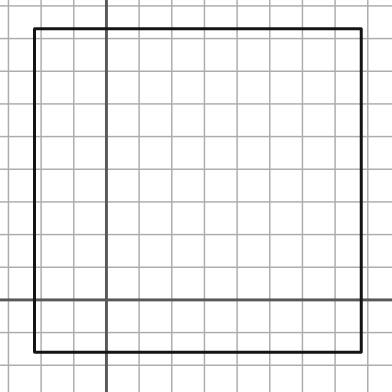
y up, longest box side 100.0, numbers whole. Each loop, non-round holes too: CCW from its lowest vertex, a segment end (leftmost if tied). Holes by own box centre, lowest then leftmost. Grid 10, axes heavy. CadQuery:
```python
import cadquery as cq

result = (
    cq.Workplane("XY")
    .moveTo(-22.0, -16.0)
    .lineTo(78.0, -16.0)
    .lineTo(78.0, 83.0)
    .lineTo(-22.0, 83.0)
    .close()
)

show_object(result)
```